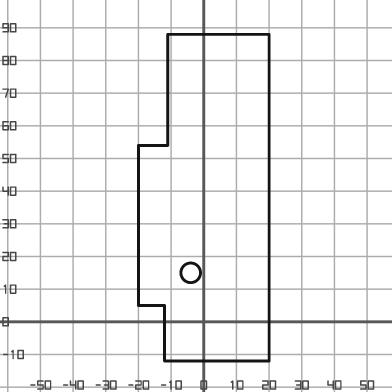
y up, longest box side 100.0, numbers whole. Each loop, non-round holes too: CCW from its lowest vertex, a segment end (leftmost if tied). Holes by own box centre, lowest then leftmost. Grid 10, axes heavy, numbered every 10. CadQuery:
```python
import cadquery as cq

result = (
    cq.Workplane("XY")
    .moveTo(-12.0, -12.0)
    .lineTo(20.0, -12.0)
    .lineTo(20.0, 88.0)
    .lineTo(-11.0, 88.0)
    .lineTo(-11.0, 54.0)
    .lineTo(-20.0, 54.0)
    .lineTo(-20.0, 5.0)
    .lineTo(-12.0, 5.0)
    .close()
    .moveTo(-4.0, 15.0)
    .circle(3.0)
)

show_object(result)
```